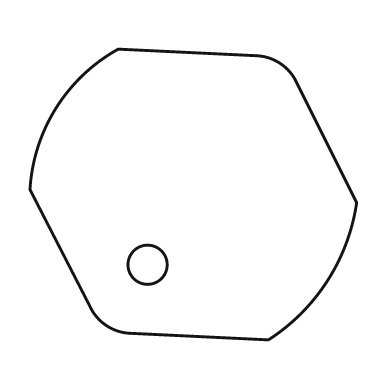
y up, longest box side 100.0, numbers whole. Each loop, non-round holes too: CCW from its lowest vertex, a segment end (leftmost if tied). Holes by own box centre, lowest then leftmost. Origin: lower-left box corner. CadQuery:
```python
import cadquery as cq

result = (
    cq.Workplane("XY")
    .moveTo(73.0, 0.0)
    .threePointArc((91.0, 18.0), (100.0, 42.0))
    .lineTo(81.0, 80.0)
    .threePointArc((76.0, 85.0), (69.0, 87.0))
    .lineTo(27.0, 89.0)
    .threePointArc((8.0, 71.0), (0.0, 46.0))
    .lineTo(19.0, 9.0)
    .threePointArc((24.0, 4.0), (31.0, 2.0))
    .close()
    .moveTo(36.0, 23.0)
    .circle(6.0)
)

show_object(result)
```